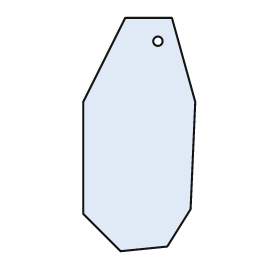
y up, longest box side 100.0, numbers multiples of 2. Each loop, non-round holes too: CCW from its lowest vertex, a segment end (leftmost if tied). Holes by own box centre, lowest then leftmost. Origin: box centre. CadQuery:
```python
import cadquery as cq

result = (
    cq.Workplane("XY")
    .moveTo(-8.0, -50.0)
    .lineTo(12.0, -48.0)
    .lineTo(22.0, -32.0)
    .lineTo(24.0, 14.0)
    .lineTo(14.0, 50.0)
    .lineTo(-6.0, 50.0)
    .lineTo(-24.0, 14.0)
    .lineTo(-24.0, -34.0)
    .close()
    .moveTo(8.0, 40.0)
    .circle(2.0)
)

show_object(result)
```